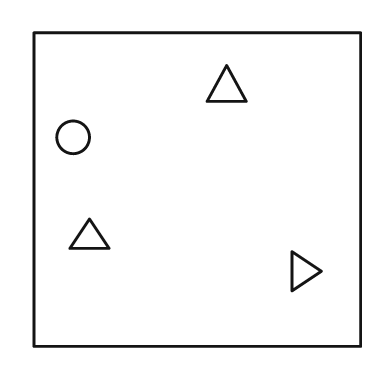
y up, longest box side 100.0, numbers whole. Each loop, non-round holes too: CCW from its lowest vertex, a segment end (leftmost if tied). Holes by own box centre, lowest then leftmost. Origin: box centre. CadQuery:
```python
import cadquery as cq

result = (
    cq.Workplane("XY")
    .moveTo(-50.0, -48.0)
    .lineTo(50.0, -48.0)
    .lineTo(50.0, 48.0)
    .lineTo(-50.0, 48.0)
    .close()
    .moveTo(29.0, -31.0)
    .lineTo(38.0, -25.0)
    .lineTo(29.0, -19.0)
    .close()
    .moveTo(-39.0, -18.0)
    .lineTo(-27.0, -18.0)
    .lineTo(-33.0, -9.0)
    .close()
    .moveTo(-38.0, 16.0)
    .circle(5.0)
    .moveTo(3.0, 27.0)
    .lineTo(15.0, 27.0)
    .lineTo(9.0, 38.0)
    .close()
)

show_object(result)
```